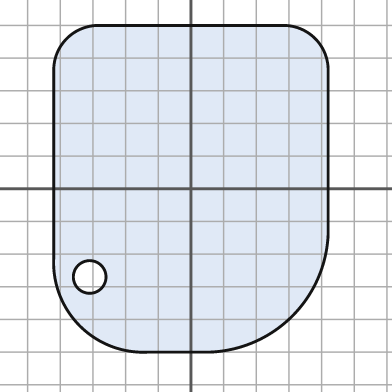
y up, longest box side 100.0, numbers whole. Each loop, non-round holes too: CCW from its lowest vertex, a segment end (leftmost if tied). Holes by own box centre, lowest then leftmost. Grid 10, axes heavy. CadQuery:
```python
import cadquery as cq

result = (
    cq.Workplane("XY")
    .moveTo(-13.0, -50.0)
    .lineTo(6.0, -50.0)
    .threePointArc((31.0, -39.0), (42.0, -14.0))
    .lineTo(42.0, 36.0)
    .threePointArc((38.0, 46.0), (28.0, 50.0))
    .lineTo(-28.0, 50.0)
    .threePointArc((-38.0, 46.0), (-42.0, 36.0))
    .lineTo(-42.0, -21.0)
    .threePointArc((-34.0, -42.0), (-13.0, -50.0))
    .close()
    .moveTo(-31.0, -27.0)
    .circle(5.0)
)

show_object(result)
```